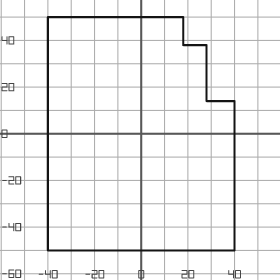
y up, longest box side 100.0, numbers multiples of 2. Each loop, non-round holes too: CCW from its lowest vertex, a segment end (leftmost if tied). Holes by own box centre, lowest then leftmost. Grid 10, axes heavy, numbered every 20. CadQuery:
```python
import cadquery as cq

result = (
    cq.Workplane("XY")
    .moveTo(-40.0, -50.0)
    .lineTo(40.0, -50.0)
    .lineTo(40.0, 14.0)
    .lineTo(28.0, 14.0)
    .lineTo(28.0, 38.0)
    .lineTo(18.0, 38.0)
    .lineTo(18.0, 50.0)
    .lineTo(-40.0, 50.0)
    .close()
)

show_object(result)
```